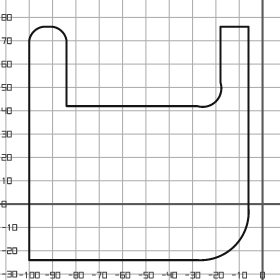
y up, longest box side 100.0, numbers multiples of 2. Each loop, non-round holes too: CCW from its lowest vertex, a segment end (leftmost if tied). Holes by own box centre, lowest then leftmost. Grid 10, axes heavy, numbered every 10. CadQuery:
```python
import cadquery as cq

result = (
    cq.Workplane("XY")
    .moveTo(-100.0, -24.0)
    .lineTo(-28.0, -24.0)
    .threePointArc((-12.0, -18.0), (-6.0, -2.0))
    .lineTo(-6.0, 76.0)
    .lineTo(-18.0, 76.0)
    .lineTo(-18.0, 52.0)
    .threePointArc((-20.0, 44.0), (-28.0, 42.0))
    .lineTo(-84.0, 42.0)
    .lineTo(-84.0, 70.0)
    .threePointArc((-86.0, 74.0), (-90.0, 76.0))
    .lineTo(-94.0, 76.0)
    .threePointArc((-98.0, 74.0), (-100.0, 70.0))
    .close()
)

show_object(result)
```